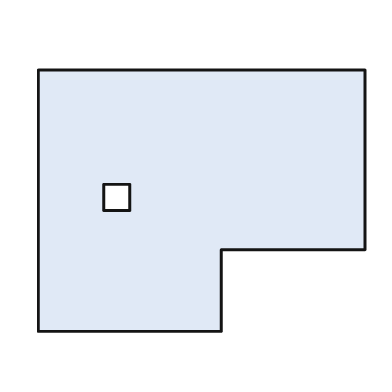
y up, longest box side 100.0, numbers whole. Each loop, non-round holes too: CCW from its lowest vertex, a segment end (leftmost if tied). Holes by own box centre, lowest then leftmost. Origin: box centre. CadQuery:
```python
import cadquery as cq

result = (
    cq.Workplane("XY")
    .moveTo(-50.0, -40.0)
    .lineTo(6.0, -40.0)
    .lineTo(6.0, -15.0)
    .lineTo(50.0, -15.0)
    .lineTo(50.0, 40.0)
    .lineTo(-50.0, 40.0)
    .close()
    .moveTo(-30.0, -3.0)
    .lineTo(-22.0, -3.0)
    .lineTo(-22.0, 5.0)
    .lineTo(-30.0, 5.0)
    .close()
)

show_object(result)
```